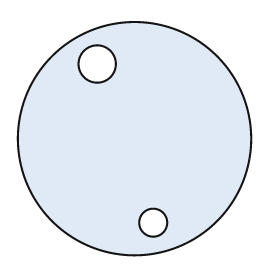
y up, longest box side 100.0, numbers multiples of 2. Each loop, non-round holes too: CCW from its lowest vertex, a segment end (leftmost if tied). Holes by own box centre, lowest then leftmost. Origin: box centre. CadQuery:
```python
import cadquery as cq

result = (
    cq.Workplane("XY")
    .moveTo(0.0, 0.0)
    .circle(50.0)
    .moveTo(8.0, -36.0)
    .circle(6.0)
    .moveTo(-16.0, 32.0)
    .circle(8.0)
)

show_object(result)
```